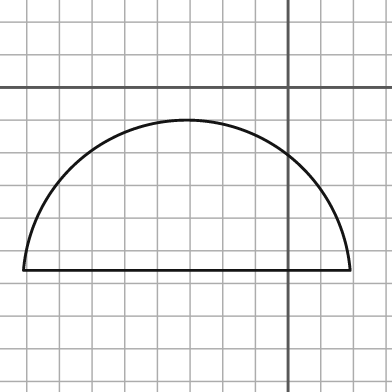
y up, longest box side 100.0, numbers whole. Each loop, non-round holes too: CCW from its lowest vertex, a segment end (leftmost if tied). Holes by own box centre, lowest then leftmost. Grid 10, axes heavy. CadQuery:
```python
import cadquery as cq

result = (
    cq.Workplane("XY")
    .moveTo(-81.0, -56.0)
    .lineTo(19.0, -56.0)
    .threePointArc((-31.0, -10.0), (-81.0, -56.0))
    .close()
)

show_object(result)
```